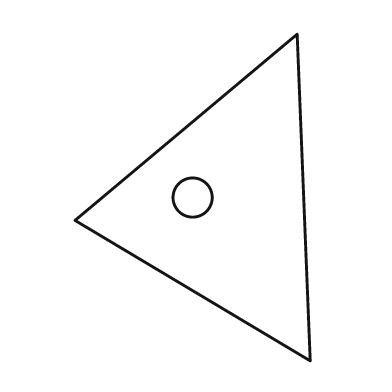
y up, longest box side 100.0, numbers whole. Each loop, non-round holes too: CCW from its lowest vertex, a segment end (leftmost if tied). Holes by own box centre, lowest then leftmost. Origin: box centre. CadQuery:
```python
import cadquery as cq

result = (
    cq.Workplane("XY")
    .moveTo(36.0, -50.0)
    .lineTo(32.0, 50.0)
    .lineTo(-36.0, -7.0)
    .close()
    .moveTo(0.0, 0.0)
    .circle(6.0)
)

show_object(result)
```